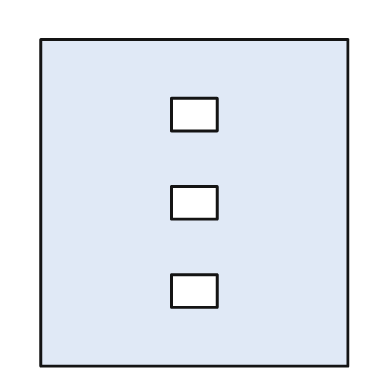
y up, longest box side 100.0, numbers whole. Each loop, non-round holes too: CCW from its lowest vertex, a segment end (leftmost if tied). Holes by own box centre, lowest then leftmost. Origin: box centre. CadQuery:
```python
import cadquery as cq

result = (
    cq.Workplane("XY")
    .moveTo(-47.0, -50.0)
    .lineTo(47.0, -50.0)
    .lineTo(47.0, 50.0)
    .lineTo(-47.0, 50.0)
    .close()
    .moveTo(-7.0, -32.0)
    .lineTo(7.0, -32.0)
    .lineTo(7.0, -22.0)
    .lineTo(-7.0, -22.0)
    .close()
    .moveTo(-7.0, -5.0)
    .lineTo(7.0, -5.0)
    .lineTo(7.0, 5.0)
    .lineTo(-7.0, 5.0)
    .close()
    .moveTo(-7.0, 22.0)
    .lineTo(7.0, 22.0)
    .lineTo(7.0, 32.0)
    .lineTo(-7.0, 32.0)
    .close()
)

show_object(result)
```